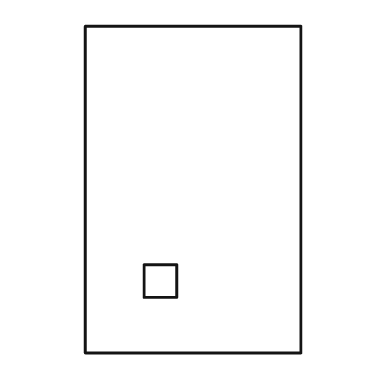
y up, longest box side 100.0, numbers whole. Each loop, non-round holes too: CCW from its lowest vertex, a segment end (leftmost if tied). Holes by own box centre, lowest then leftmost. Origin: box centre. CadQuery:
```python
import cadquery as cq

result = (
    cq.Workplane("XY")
    .moveTo(-33.0, -50.0)
    .lineTo(33.0, -50.0)
    .lineTo(33.0, 50.0)
    .lineTo(-33.0, 50.0)
    .close()
    .moveTo(-15.0, -33.0)
    .lineTo(-5.0, -33.0)
    .lineTo(-5.0, -23.0)
    .lineTo(-15.0, -23.0)
    .close()
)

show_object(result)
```